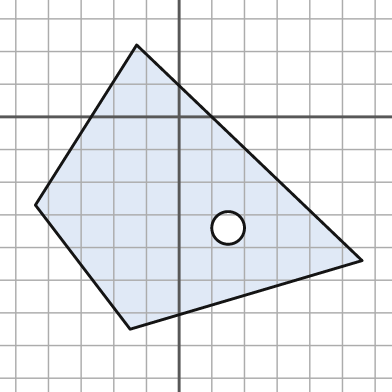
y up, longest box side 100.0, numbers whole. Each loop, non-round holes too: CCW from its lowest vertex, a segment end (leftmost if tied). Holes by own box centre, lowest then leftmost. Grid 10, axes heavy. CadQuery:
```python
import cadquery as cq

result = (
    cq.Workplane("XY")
    .moveTo(-15.0, -65.0)
    .lineTo(56.0, -44.0)
    .lineTo(-13.0, 22.0)
    .lineTo(-44.0, -27.0)
    .close()
    .moveTo(15.0, -34.0)
    .circle(5.0)
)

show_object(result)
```